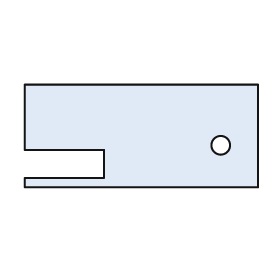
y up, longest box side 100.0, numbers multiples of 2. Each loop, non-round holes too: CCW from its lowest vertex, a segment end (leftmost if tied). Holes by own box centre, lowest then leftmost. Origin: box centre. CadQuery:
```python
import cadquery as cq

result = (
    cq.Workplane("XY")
    .moveTo(-50.0, -22.0)
    .lineTo(50.0, -22.0)
    .lineTo(50.0, 22.0)
    .lineTo(-50.0, 22.0)
    .lineTo(-50.0, -6.0)
    .lineTo(-16.0, -6.0)
    .lineTo(-16.0, -18.0)
    .lineTo(-50.0, -18.0)
    .close()
    .moveTo(34.0, -4.0)
    .circle(4.0)
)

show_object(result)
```